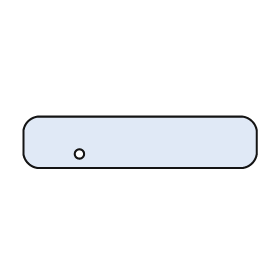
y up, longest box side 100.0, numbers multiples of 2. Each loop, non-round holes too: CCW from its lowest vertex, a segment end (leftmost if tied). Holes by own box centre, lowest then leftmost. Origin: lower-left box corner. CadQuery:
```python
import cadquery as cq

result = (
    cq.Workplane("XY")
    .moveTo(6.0, 0.0)
    .lineTo(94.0, 0.0)
    .threePointArc((98.0, 2.0), (100.0, 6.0))
    .lineTo(100.0, 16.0)
    .threePointArc((98.0, 20.0), (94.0, 22.0))
    .lineTo(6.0, 22.0)
    .threePointArc((2.0, 20.0), (0.0, 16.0))
    .lineTo(0.0, 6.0)
    .threePointArc((2.0, 2.0), (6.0, 0.0))
    .close()
    .moveTo(24.0, 6.0)
    .circle(2.0)
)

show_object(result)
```